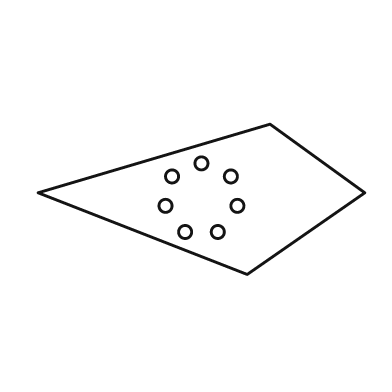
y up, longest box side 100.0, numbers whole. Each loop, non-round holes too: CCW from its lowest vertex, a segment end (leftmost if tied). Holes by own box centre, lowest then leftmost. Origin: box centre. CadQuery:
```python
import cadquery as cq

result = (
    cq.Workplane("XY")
    .moveTo(14.0, -23.0)
    .lineTo(50.0, 2.0)
    .lineTo(21.0, 23.0)
    .lineTo(-50.0, 2.0)
    .close()
    .moveTo(-5.0, -10.0)
    .circle(2.0)
    .moveTo(5.0, -10.0)
    .circle(2.0)
    .moveTo(-11.0, -2.0)
    .circle(2.0)
    .moveTo(11.0, -2.0)
    .circle(2.0)
    .moveTo(-9.0, 7.0)
    .circle(2.0)
    .moveTo(9.0, 7.0)
    .circle(2.0)
    .moveTo(0.0, 11.0)
    .circle(2.0)
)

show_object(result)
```